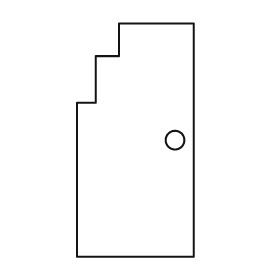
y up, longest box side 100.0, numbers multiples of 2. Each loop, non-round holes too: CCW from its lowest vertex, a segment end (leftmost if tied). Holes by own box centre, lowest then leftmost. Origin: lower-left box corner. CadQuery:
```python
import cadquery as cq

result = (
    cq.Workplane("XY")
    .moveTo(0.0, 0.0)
    .lineTo(50.0, 0.0)
    .lineTo(50.0, 100.0)
    .lineTo(18.0, 100.0)
    .lineTo(18.0, 86.0)
    .lineTo(8.0, 86.0)
    .lineTo(8.0, 66.0)
    .lineTo(0.0, 66.0)
    .close()
    .moveTo(42.0, 50.0)
    .circle(4.0)
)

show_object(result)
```